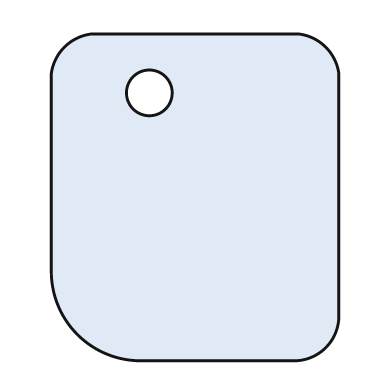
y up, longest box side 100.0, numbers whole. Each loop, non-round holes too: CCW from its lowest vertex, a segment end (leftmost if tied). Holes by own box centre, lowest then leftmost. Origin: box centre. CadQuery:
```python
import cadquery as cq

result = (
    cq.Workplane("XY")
    .moveTo(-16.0, -50.0)
    .lineTo(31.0, -50.0)
    .threePointArc((40.0, -46.0), (44.0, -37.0))
    .lineTo(44.0, 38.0)
    .threePointArc((40.0, 46.0), (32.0, 50.0))
    .lineTo(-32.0, 50.0)
    .threePointArc((-40.0, 46.0), (-44.0, 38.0))
    .lineTo(-44.0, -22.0)
    .threePointArc((-36.0, -42.0), (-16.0, -50.0))
    .close()
    .moveTo(-14.0, 32.0)
    .circle(7.0)
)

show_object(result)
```